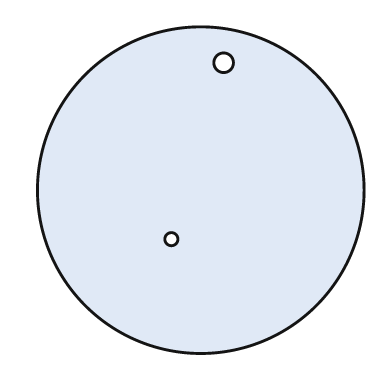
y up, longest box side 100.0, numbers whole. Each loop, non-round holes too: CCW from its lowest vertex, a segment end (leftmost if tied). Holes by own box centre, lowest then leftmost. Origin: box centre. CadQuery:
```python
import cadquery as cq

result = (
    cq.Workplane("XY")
    .moveTo(0.0, 0.0)
    .circle(50.0)
    .moveTo(-9.0, -15.0)
    .circle(2.0)
    .moveTo(7.0, 39.0)
    .circle(3.0)
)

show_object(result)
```